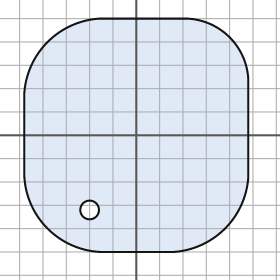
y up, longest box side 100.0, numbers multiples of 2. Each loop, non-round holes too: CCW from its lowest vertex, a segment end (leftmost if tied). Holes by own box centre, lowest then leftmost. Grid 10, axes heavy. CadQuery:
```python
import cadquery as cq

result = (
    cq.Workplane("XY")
    .moveTo(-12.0, -50.0)
    .lineTo(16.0, -50.0)
    .threePointArc((38.0, -40.0), (48.0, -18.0))
    .lineTo(48.0, 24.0)
    .threePointArc((40.0, 42.0), (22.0, 50.0))
    .lineTo(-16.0, 50.0)
    .threePointArc((-38.0, 40.0), (-48.0, 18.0))
    .lineTo(-48.0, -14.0)
    .threePointArc((-38.0, -40.0), (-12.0, -50.0))
    .close()
    .moveTo(-20.0, -32.0)
    .circle(4.0)
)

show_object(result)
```